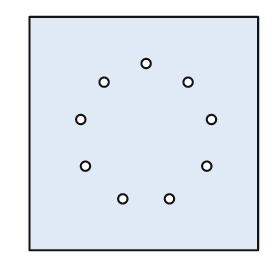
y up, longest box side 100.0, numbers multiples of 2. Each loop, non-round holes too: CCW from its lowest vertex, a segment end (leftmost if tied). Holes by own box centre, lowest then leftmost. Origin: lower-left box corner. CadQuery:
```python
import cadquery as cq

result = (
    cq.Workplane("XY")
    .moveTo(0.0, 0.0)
    .lineTo(98.0, 0.0)
    .lineTo(98.0, 100.0)
    .lineTo(0.0, 100.0)
    .close()
    .moveTo(40.0, 22.0)
    .circle(2.0)
    .moveTo(60.0, 22.0)
    .circle(2.0)
    .moveTo(24.0, 36.0)
    .circle(2.0)
    .moveTo(76.0, 36.0)
    .circle(2.0)
    .moveTo(22.0, 56.0)
    .circle(2.0)
    .moveTo(78.0, 56.0)
    .circle(2.0)
    .moveTo(32.0, 72.0)
    .circle(2.0)
    .moveTo(68.0, 72.0)
    .circle(2.0)
    .moveTo(50.0, 80.0)
    .circle(2.0)
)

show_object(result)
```